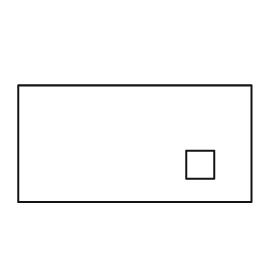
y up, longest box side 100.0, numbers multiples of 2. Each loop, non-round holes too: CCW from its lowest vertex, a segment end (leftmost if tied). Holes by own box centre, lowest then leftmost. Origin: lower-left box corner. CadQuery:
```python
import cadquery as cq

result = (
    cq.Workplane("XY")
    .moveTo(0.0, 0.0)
    .lineTo(100.0, 0.0)
    .lineTo(100.0, 50.0)
    .lineTo(0.0, 50.0)
    .close()
    .moveTo(72.0, 10.0)
    .lineTo(84.0, 10.0)
    .lineTo(84.0, 22.0)
    .lineTo(72.0, 22.0)
    .close()
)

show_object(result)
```